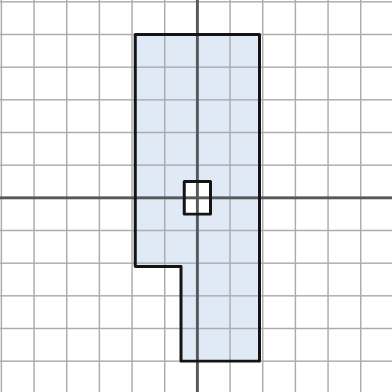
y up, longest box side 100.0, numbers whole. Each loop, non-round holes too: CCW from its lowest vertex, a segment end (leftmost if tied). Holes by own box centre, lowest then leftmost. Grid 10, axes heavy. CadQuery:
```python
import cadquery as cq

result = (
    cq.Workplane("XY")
    .moveTo(-5.0, -50.0)
    .lineTo(19.0, -50.0)
    .lineTo(19.0, 50.0)
    .lineTo(-19.0, 50.0)
    .lineTo(-19.0, -21.0)
    .lineTo(-5.0, -21.0)
    .close()
    .moveTo(-4.0, -5.0)
    .lineTo(4.0, -5.0)
    .lineTo(4.0, 5.0)
    .lineTo(-4.0, 5.0)
    .close()
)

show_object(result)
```